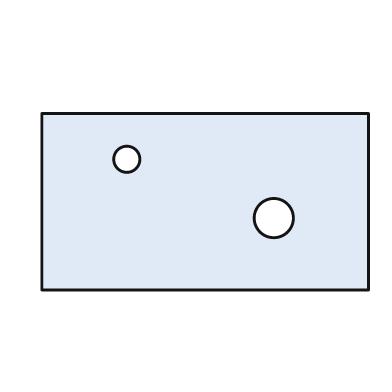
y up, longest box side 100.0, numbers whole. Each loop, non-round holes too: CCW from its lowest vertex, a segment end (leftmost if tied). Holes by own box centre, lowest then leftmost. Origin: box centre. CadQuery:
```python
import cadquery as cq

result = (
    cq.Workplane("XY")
    .moveTo(-50.0, -27.0)
    .lineTo(50.0, -27.0)
    .lineTo(50.0, 27.0)
    .lineTo(-50.0, 27.0)
    .close()
    .moveTo(21.0, -5.0)
    .circle(6.0)
    .moveTo(-24.0, 13.0)
    .circle(4.0)
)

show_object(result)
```